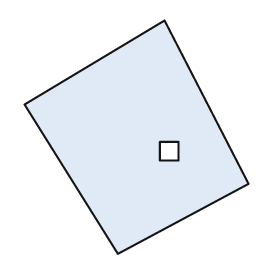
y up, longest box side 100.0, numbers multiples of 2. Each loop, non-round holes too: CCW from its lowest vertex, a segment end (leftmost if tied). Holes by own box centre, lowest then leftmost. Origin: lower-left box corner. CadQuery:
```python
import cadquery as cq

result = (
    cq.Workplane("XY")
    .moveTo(40.0, 0.0)
    .lineTo(96.0, 30.0)
    .lineTo(60.0, 100.0)
    .lineTo(0.0, 64.0)
    .close()
    .moveTo(58.0, 40.0)
    .lineTo(66.0, 40.0)
    .lineTo(66.0, 48.0)
    .lineTo(58.0, 48.0)
    .close()
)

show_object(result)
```